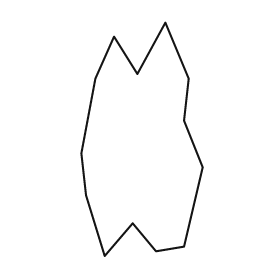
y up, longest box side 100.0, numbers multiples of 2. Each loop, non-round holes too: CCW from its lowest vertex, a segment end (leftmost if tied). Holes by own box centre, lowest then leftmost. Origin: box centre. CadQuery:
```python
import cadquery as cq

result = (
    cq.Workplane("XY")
    .moveTo(-16.0, -50.0)
    .lineTo(-4.0, -36.0)
    .lineTo(6.0, -48.0)
    .lineTo(18.0, -46.0)
    .lineTo(26.0, -12.0)
    .lineTo(18.0, 8.0)
    .lineTo(20.0, 26.0)
    .lineTo(10.0, 50.0)
    .lineTo(-2.0, 28.0)
    .lineTo(-12.0, 44.0)
    .lineTo(-20.0, 26.0)
    .lineTo(-26.0, -6.0)
    .lineTo(-24.0, -24.0)
    .close()
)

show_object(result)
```